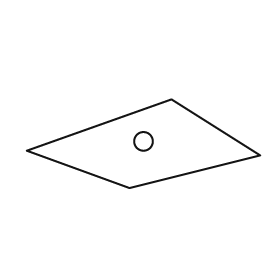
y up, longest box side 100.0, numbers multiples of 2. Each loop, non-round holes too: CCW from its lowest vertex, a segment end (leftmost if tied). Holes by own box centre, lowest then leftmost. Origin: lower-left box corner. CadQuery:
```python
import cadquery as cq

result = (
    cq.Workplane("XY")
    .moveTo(44.0, 0.0)
    .lineTo(100.0, 14.0)
    .lineTo(62.0, 38.0)
    .lineTo(0.0, 16.0)
    .close()
    .moveTo(50.0, 20.0)
    .circle(4.0)
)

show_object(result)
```